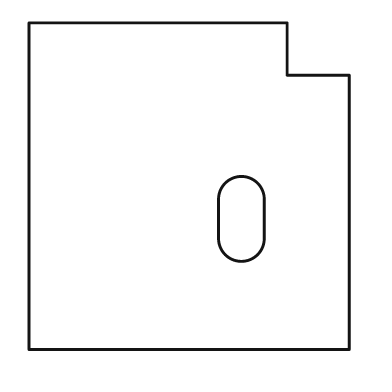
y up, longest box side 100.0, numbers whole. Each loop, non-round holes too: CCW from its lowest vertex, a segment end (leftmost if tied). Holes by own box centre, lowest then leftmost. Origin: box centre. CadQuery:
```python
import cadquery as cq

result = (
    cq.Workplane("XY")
    .moveTo(-49.0, -50.0)
    .lineTo(49.0, -50.0)
    .lineTo(49.0, 34.0)
    .lineTo(30.0, 34.0)
    .lineTo(30.0, 50.0)
    .lineTo(-49.0, 50.0)
    .close()
    .moveTo(9.0, -16.0)
    .threePointArc((16.0, -23.0), (23.0, -16.0))
    .lineTo(23.0, -4.0)
    .threePointArc((16.0, 3.0), (9.0, -4.0))
    .close()
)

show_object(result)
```